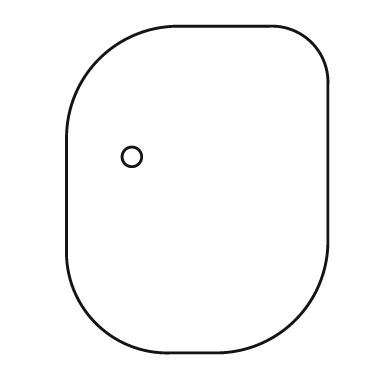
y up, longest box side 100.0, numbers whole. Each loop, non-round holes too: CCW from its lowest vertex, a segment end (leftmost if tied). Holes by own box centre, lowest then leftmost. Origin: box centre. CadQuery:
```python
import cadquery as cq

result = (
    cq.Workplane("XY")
    .moveTo(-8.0, -50.0)
    .lineTo(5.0, -50.0)
    .threePointArc((30.0, -40.0), (40.0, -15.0))
    .lineTo(40.0, 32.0)
    .threePointArc((35.0, 45.0), (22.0, 50.0))
    .lineTo(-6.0, 50.0)
    .threePointArc((-30.0, 40.0), (-40.0, 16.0))
    .lineTo(-40.0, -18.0)
    .threePointArc((-31.0, -41.0), (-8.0, -50.0))
    .close()
    .moveTo(-20.0, 10.0)
    .circle(3.0)
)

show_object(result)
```